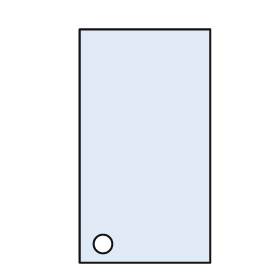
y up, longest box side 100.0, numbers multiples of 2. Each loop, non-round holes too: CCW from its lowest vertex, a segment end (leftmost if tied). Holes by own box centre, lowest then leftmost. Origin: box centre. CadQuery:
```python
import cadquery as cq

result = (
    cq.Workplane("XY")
    .moveTo(-28.0, -50.0)
    .lineTo(28.0, -50.0)
    .lineTo(28.0, 50.0)
    .lineTo(-28.0, 50.0)
    .close()
    .moveTo(-18.0, -42.0)
    .circle(4.0)
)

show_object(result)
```